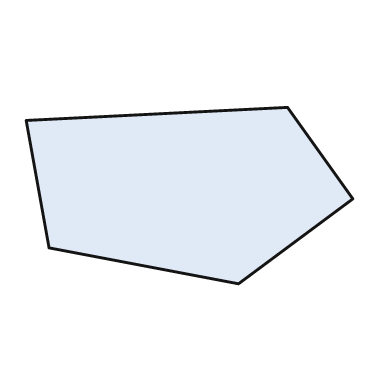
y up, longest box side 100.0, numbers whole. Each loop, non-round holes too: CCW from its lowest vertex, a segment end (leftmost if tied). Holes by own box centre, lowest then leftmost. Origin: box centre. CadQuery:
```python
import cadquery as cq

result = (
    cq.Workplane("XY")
    .moveTo(15.0, -27.0)
    .lineTo(50.0, -1.0)
    .lineTo(30.0, 27.0)
    .lineTo(-50.0, 23.0)
    .lineTo(-43.0, -16.0)
    .close()
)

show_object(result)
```